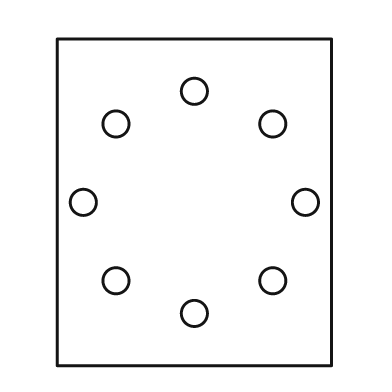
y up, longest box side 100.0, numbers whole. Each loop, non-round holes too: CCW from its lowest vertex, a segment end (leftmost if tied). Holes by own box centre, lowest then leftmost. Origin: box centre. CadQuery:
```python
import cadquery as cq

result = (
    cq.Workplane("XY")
    .moveTo(-42.0, -50.0)
    .lineTo(42.0, -50.0)
    .lineTo(42.0, 50.0)
    .lineTo(-42.0, 50.0)
    .close()
    .moveTo(0.0, -34.0)
    .circle(4.0)
    .moveTo(-24.0, -24.0)
    .circle(4.0)
    .moveTo(24.0, -24.0)
    .circle(4.0)
    .moveTo(-34.0, 0.0)
    .circle(4.0)
    .moveTo(34.0, 0.0)
    .circle(4.0)
    .moveTo(-24.0, 24.0)
    .circle(4.0)
    .moveTo(24.0, 24.0)
    .circle(4.0)
    .moveTo(0.0, 34.0)
    .circle(4.0)
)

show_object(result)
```